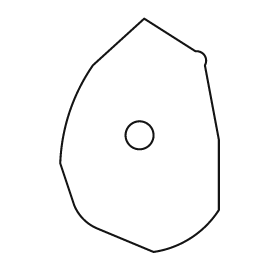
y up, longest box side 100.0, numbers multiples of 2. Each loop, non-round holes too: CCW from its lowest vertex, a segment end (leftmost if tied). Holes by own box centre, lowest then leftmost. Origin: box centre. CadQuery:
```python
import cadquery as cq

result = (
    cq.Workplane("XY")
    .moveTo(6.0, -50.0)
    .threePointArc((22.0, -44.0), (34.0, -32.0))
    .lineTo(34.0, -2.0)
    .lineTo(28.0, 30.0)
    .threePointArc((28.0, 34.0), (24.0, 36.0))
    .lineTo(2.0, 50.0)
    .lineTo(-20.0, 30.0)
    .threePointArc((-30.0, 10.0), (-34.0, -12.0))
    .lineTo(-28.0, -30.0)
    .threePointArc((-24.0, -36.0), (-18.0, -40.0))
    .close()
    .moveTo(0.0, 0.0)
    .circle(6.0)
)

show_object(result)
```